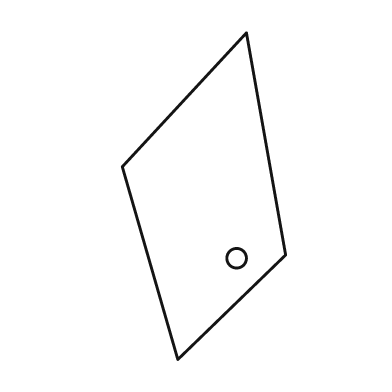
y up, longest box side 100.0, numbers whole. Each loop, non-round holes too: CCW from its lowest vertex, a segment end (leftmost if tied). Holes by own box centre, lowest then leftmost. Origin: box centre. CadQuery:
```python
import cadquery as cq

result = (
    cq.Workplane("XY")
    .moveTo(-8.0, -50.0)
    .lineTo(25.0, -18.0)
    .lineTo(13.0, 50.0)
    .lineTo(-25.0, 9.0)
    .close()
    .moveTo(10.0, -19.0)
    .circle(3.0)
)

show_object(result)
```